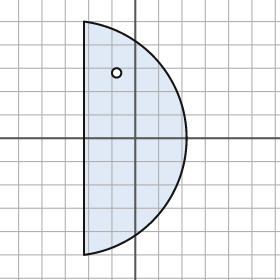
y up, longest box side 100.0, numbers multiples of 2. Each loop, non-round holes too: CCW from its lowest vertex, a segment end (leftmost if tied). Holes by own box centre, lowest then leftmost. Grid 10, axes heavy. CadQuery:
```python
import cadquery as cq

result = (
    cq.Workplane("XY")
    .moveTo(-22.0, -50.0)
    .threePointArc((22.0, 0.0), (-22.0, 50.0))
    .close()
    .moveTo(-8.0, 28.0)
    .circle(2.0)
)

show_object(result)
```